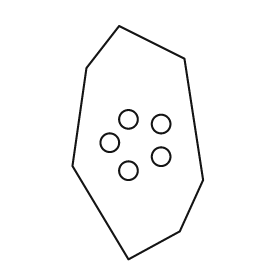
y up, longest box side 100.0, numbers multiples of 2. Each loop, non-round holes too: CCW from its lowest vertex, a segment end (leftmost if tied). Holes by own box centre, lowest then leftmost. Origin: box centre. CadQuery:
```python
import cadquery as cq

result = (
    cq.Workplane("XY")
    .moveTo(-4.0, -50.0)
    .lineTo(18.0, -38.0)
    .lineTo(28.0, -16.0)
    .lineTo(20.0, 36.0)
    .lineTo(-8.0, 50.0)
    .lineTo(-22.0, 32.0)
    .lineTo(-28.0, -10.0)
    .close()
    .moveTo(-4.0, -12.0)
    .circle(4.0)
    .moveTo(10.0, -6.0)
    .circle(4.0)
    .moveTo(-12.0, 0.0)
    .circle(4.0)
    .moveTo(10.0, 8.0)
    .circle(4.0)
    .moveTo(-4.0, 10.0)
    .circle(4.0)
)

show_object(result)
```